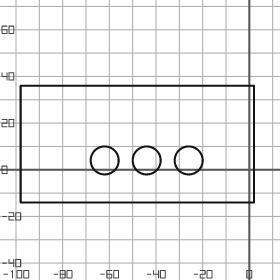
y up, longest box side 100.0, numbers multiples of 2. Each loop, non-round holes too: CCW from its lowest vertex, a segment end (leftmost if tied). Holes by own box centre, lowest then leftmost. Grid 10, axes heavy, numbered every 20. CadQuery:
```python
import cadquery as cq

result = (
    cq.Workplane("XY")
    .moveTo(-98.0, -14.0)
    .lineTo(2.0, -14.0)
    .lineTo(2.0, 36.0)
    .lineTo(-98.0, 36.0)
    .close()
    .moveTo(-62.0, 4.0)
    .circle(6.0)
    .moveTo(-44.0, 4.0)
    .circle(6.0)
    .moveTo(-26.0, 4.0)
    .circle(6.0)
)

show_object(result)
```